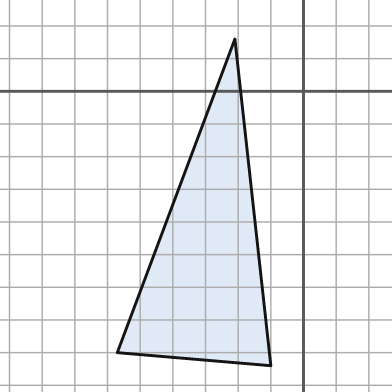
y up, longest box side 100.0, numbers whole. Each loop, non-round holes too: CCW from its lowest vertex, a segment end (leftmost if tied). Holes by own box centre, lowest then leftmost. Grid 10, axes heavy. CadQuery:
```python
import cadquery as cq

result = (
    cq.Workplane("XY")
    .moveTo(-10.0, -84.0)
    .lineTo(-21.0, 16.0)
    .lineTo(-57.0, -80.0)
    .close()
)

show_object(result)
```